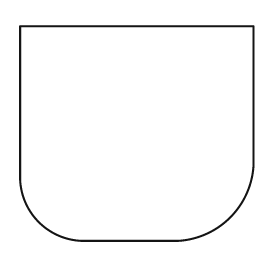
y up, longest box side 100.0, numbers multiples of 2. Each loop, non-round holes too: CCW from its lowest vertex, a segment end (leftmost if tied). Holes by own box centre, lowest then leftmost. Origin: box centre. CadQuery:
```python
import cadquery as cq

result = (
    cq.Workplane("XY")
    .moveTo(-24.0, -46.0)
    .lineTo(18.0, -46.0)
    .threePointArc((40.0, -36.0), (50.0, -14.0))
    .lineTo(50.0, 46.0)
    .lineTo(-50.0, 46.0)
    .lineTo(-50.0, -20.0)
    .threePointArc((-42.0, -38.0), (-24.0, -46.0))
    .close()
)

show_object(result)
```